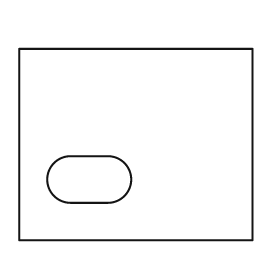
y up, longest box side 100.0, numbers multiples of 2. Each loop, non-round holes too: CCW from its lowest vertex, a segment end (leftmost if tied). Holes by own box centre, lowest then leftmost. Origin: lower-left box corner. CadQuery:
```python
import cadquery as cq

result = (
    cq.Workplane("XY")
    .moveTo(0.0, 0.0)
    .lineTo(100.0, 0.0)
    .lineTo(100.0, 82.0)
    .lineTo(0.0, 82.0)
    .close()
    .moveTo(22.0, 16.0)
    .lineTo(38.0, 16.0)
    .threePointArc((48.0, 26.0), (38.0, 36.0))
    .lineTo(22.0, 36.0)
    .threePointArc((12.0, 26.0), (22.0, 16.0))
    .close()
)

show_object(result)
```